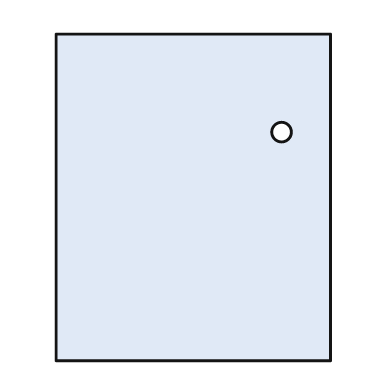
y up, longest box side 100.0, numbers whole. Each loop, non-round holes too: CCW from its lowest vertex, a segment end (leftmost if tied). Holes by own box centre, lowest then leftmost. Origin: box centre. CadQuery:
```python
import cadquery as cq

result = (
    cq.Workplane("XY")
    .moveTo(-42.0, -50.0)
    .lineTo(42.0, -50.0)
    .lineTo(42.0, 50.0)
    .lineTo(-42.0, 50.0)
    .close()
    .moveTo(27.0, 20.0)
    .circle(3.0)
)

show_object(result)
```